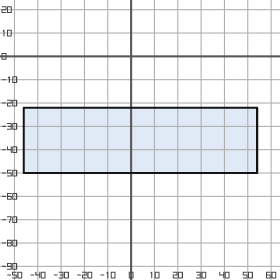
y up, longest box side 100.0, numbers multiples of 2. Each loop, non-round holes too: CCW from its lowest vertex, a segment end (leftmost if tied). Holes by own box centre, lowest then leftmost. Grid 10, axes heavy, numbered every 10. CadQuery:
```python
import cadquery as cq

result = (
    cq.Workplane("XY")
    .moveTo(-46.0, -50.0)
    .lineTo(54.0, -50.0)
    .lineTo(54.0, -22.0)
    .lineTo(-46.0, -22.0)
    .close()
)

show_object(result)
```